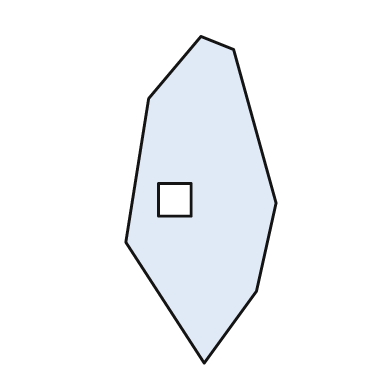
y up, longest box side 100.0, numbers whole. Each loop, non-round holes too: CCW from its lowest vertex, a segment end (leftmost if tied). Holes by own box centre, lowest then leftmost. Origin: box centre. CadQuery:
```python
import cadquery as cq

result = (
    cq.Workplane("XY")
    .moveTo(1.0, -50.0)
    .lineTo(17.0, -28.0)
    .lineTo(23.0, -1.0)
    .lineTo(10.0, 46.0)
    .lineTo(0.0, 50.0)
    .lineTo(-16.0, 31.0)
    .lineTo(-23.0, -13.0)
    .close()
    .moveTo(-13.0, -5.0)
    .lineTo(-3.0, -5.0)
    .lineTo(-3.0, 5.0)
    .lineTo(-13.0, 5.0)
    .close()
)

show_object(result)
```